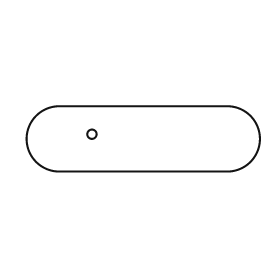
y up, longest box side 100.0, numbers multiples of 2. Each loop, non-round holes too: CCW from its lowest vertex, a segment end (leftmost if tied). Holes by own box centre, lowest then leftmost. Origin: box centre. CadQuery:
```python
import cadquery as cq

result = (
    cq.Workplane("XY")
    .moveTo(-36.0, -14.0)
    .lineTo(36.0, -14.0)
    .threePointArc((50.0, 0.0), (36.0, 14.0))
    .lineTo(-36.0, 14.0)
    .threePointArc((-50.0, 0.0), (-36.0, -14.0))
    .close()
    .moveTo(-22.0, 2.0)
    .circle(2.0)
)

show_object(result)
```